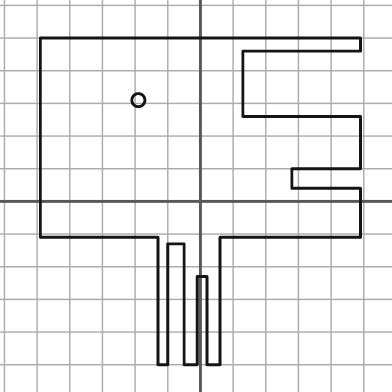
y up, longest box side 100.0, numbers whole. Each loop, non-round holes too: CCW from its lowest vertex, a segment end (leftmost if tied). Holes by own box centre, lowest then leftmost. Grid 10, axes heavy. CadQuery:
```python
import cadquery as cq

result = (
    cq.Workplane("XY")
    .moveTo(-13.0, -50.0)
    .lineTo(-10.0, -50.0)
    .lineTo(-10.0, -13.0)
    .lineTo(-5.0, -13.0)
    .lineTo(-5.0, -50.0)
    .lineTo(-1.0, -50.0)
    .lineTo(-1.0, -23.0)
    .lineTo(2.0, -23.0)
    .lineTo(2.0, -50.0)
    .lineTo(6.0, -50.0)
    .lineTo(6.0, -11.0)
    .lineTo(49.0, -11.0)
    .lineTo(49.0, 4.0)
    .lineTo(28.0, 4.0)
    .lineTo(28.0, 10.0)
    .lineTo(49.0, 10.0)
    .lineTo(49.0, 26.0)
    .lineTo(13.0, 26.0)
    .lineTo(13.0, 46.0)
    .lineTo(49.0, 46.0)
    .lineTo(49.0, 50.0)
    .lineTo(-49.0, 50.0)
    .lineTo(-49.0, -11.0)
    .lineTo(-13.0, -11.0)
    .close()
    .moveTo(-19.0, 31.0)
    .circle(2.0)
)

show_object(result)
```